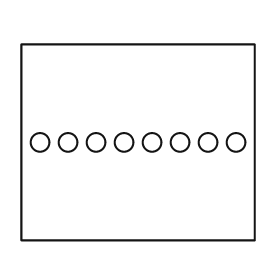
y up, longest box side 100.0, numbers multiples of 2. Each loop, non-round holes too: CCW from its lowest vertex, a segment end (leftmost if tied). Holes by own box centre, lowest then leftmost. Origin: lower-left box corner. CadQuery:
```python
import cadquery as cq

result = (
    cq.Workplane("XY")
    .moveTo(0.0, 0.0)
    .lineTo(100.0, 0.0)
    .lineTo(100.0, 84.0)
    .lineTo(0.0, 84.0)
    .close()
    .moveTo(8.0, 42.0)
    .circle(4.0)
    .moveTo(20.0, 42.0)
    .circle(4.0)
    .moveTo(32.0, 42.0)
    .circle(4.0)
    .moveTo(44.0, 42.0)
    .circle(4.0)
    .moveTo(56.0, 42.0)
    .circle(4.0)
    .moveTo(68.0, 42.0)
    .circle(4.0)
    .moveTo(80.0, 42.0)
    .circle(4.0)
    .moveTo(92.0, 42.0)
    .circle(4.0)
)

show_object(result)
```